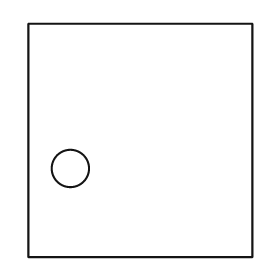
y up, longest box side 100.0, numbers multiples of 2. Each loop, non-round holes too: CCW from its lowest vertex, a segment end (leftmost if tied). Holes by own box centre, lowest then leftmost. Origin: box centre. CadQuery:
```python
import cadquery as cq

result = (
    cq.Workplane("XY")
    .moveTo(-48.0, -50.0)
    .lineTo(48.0, -50.0)
    .lineTo(48.0, 50.0)
    .lineTo(-48.0, 50.0)
    .close()
    .moveTo(-30.0, -12.0)
    .circle(8.0)
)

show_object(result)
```